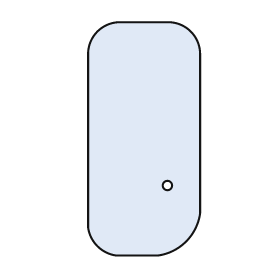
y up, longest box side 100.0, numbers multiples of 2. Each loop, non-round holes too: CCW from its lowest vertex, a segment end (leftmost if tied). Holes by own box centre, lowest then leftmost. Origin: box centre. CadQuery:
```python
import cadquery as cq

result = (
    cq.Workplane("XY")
    .moveTo(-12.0, -50.0)
    .lineTo(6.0, -50.0)
    .threePointArc((18.0, -44.0), (24.0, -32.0))
    .lineTo(24.0, 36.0)
    .threePointArc((20.0, 46.0), (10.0, 50.0))
    .lineTo(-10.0, 50.0)
    .threePointArc((-20.0, 46.0), (-24.0, 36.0))
    .lineTo(-24.0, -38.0)
    .threePointArc((-20.0, -46.0), (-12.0, -50.0))
    .close()
    .moveTo(10.0, -20.0)
    .circle(2.0)
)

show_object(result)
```